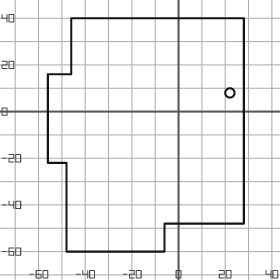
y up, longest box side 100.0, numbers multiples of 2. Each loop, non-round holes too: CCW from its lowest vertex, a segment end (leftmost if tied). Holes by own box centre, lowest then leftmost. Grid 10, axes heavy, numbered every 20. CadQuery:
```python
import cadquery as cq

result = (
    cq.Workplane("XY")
    .moveTo(-48.0, -60.0)
    .lineTo(-6.0, -60.0)
    .lineTo(-6.0, -48.0)
    .lineTo(28.0, -48.0)
    .lineTo(28.0, 40.0)
    .lineTo(-46.0, 40.0)
    .lineTo(-46.0, 16.0)
    .lineTo(-56.0, 16.0)
    .lineTo(-56.0, -22.0)
    .lineTo(-48.0, -22.0)
    .close()
    .moveTo(22.0, 8.0)
    .circle(2.0)
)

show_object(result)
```